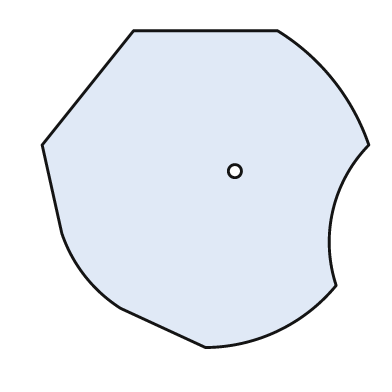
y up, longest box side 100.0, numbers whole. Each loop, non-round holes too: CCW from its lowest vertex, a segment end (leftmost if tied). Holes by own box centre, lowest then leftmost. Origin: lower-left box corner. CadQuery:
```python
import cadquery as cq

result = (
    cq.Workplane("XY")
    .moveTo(50.0, 0.0)
    .threePointArc((72.0, 5.0), (90.0, 19.0))
    .threePointArc((89.0, 42.0), (100.0, 62.0))
    .threePointArc((89.0, 82.0), (72.0, 97.0))
    .lineTo(28.0, 97.0)
    .lineTo(0.0, 62.0)
    .lineTo(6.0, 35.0)
    .threePointArc((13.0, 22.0), (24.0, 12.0))
    .close()
    .moveTo(59.0, 54.0)
    .circle(2.0)
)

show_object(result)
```